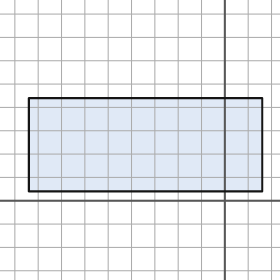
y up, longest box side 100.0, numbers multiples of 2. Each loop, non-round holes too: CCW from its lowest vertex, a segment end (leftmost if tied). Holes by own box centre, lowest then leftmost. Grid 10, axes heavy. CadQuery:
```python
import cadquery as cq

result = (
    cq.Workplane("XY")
    .moveTo(-84.0, 4.0)
    .lineTo(16.0, 4.0)
    .lineTo(16.0, 44.0)
    .lineTo(-84.0, 44.0)
    .close()
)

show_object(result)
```